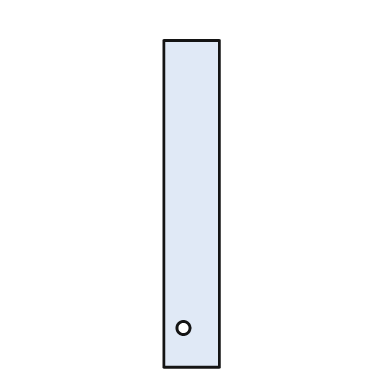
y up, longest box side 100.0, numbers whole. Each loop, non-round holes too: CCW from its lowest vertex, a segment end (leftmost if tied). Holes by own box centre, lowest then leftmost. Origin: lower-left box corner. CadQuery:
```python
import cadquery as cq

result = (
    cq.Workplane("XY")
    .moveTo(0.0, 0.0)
    .lineTo(17.0, 0.0)
    .lineTo(17.0, 100.0)
    .lineTo(0.0, 100.0)
    .close()
    .moveTo(6.0, 12.0)
    .circle(2.0)
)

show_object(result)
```